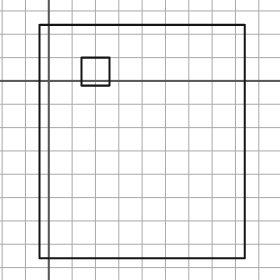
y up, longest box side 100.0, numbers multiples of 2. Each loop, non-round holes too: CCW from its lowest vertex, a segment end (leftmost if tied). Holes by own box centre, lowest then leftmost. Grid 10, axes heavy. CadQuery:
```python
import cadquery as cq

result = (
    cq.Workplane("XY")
    .moveTo(-4.0, -76.0)
    .lineTo(84.0, -76.0)
    .lineTo(84.0, 24.0)
    .lineTo(-4.0, 24.0)
    .close()
    .moveTo(14.0, -2.0)
    .lineTo(26.0, -2.0)
    .lineTo(26.0, 10.0)
    .lineTo(14.0, 10.0)
    .close()
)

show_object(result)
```